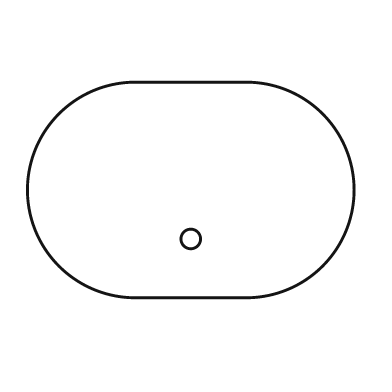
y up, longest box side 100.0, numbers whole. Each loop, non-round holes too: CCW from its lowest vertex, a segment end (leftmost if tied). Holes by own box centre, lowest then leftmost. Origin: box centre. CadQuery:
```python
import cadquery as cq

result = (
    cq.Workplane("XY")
    .moveTo(-17.0, -33.0)
    .lineTo(17.0, -33.0)
    .threePointArc((50.0, 0.0), (17.0, 33.0))
    .lineTo(-17.0, 33.0)
    .threePointArc((-50.0, 0.0), (-17.0, -33.0))
    .close()
    .moveTo(0.0, -15.0)
    .circle(3.0)
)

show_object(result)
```